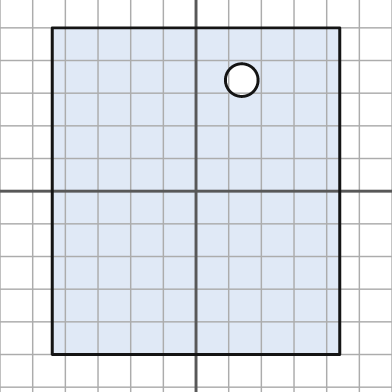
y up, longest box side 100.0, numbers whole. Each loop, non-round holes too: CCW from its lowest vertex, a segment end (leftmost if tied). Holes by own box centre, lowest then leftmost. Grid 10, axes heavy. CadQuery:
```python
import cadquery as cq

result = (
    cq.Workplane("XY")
    .moveTo(-44.0, -50.0)
    .lineTo(44.0, -50.0)
    .lineTo(44.0, 50.0)
    .lineTo(-44.0, 50.0)
    .close()
    .moveTo(14.0, 34.0)
    .circle(5.0)
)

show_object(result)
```